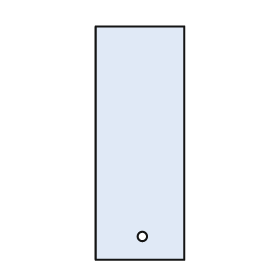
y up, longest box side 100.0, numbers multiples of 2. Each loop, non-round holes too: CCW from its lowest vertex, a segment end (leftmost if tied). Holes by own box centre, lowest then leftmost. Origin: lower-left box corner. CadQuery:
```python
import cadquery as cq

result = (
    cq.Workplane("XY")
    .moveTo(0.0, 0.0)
    .lineTo(38.0, 0.0)
    .lineTo(38.0, 100.0)
    .lineTo(0.0, 100.0)
    .close()
    .moveTo(20.0, 10.0)
    .circle(2.0)
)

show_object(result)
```